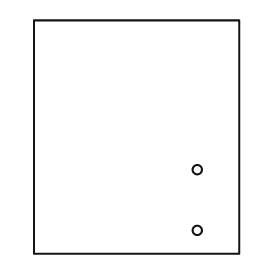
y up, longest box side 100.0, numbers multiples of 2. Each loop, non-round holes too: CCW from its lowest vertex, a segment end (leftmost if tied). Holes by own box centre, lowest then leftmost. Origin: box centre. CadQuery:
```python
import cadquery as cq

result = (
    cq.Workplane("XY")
    .moveTo(-44.0, -50.0)
    .lineTo(44.0, -50.0)
    .lineTo(44.0, 50.0)
    .lineTo(-44.0, 50.0)
    .close()
    .moveTo(26.0, -40.0)
    .circle(2.0)
    .moveTo(26.0, -14.0)
    .circle(2.0)
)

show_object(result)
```